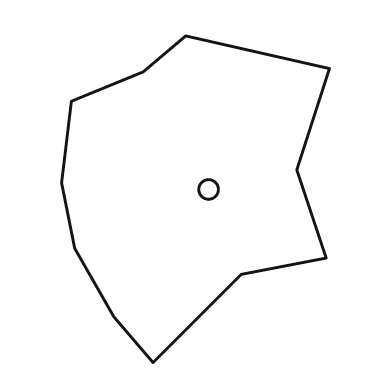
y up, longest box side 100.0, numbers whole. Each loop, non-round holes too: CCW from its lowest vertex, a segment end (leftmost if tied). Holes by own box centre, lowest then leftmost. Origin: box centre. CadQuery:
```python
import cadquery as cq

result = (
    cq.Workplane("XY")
    .moveTo(-13.0, -50.0)
    .lineTo(14.0, -23.0)
    .lineTo(40.0, -18.0)
    .lineTo(31.0, 9.0)
    .lineTo(41.0, 40.0)
    .lineTo(-3.0, 50.0)
    .lineTo(-16.0, 39.0)
    .lineTo(-38.0, 30.0)
    .lineTo(-41.0, 5.0)
    .lineTo(-37.0, -15.0)
    .lineTo(-25.0, -36.0)
    .close()
    .moveTo(4.0, 3.0)
    .circle(3.0)
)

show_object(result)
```